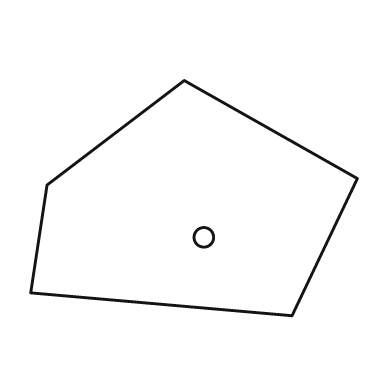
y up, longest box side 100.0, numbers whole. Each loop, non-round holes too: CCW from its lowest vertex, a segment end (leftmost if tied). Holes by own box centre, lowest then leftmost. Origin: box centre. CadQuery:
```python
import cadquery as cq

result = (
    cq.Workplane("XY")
    .moveTo(30.0, -36.0)
    .lineTo(50.0, 6.0)
    .lineTo(-3.0, 36.0)
    .lineTo(-45.0, 4.0)
    .lineTo(-50.0, -29.0)
    .close()
    .moveTo(3.0, -12.0)
    .circle(3.0)
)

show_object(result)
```